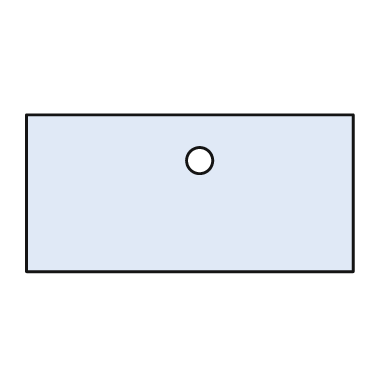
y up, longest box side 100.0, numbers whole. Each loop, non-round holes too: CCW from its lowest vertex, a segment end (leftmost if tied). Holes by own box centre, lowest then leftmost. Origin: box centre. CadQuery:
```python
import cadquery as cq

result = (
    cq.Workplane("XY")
    .moveTo(-50.0, -24.0)
    .lineTo(50.0, -24.0)
    .lineTo(50.0, 24.0)
    .lineTo(-50.0, 24.0)
    .close()
    .moveTo(3.0, 10.0)
    .circle(4.0)
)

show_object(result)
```